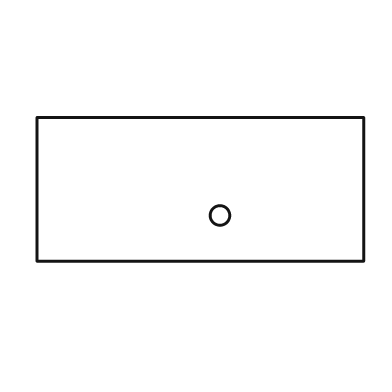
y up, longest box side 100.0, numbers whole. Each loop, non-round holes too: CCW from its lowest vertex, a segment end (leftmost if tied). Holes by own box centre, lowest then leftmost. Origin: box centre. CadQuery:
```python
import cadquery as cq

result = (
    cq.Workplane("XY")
    .moveTo(-50.0, -22.0)
    .lineTo(50.0, -22.0)
    .lineTo(50.0, 22.0)
    .lineTo(-50.0, 22.0)
    .close()
    .moveTo(6.0, -8.0)
    .circle(3.0)
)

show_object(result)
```